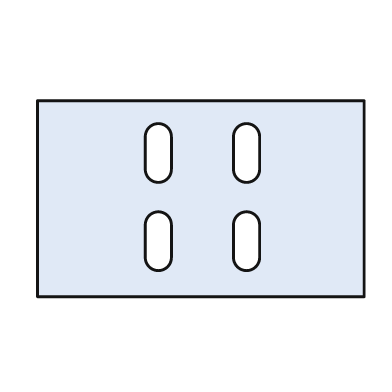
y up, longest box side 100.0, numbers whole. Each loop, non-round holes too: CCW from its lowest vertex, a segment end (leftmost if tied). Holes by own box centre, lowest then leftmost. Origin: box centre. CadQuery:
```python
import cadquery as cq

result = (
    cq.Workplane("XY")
    .moveTo(-50.0, -30.0)
    .lineTo(50.0, -30.0)
    .lineTo(50.0, 30.0)
    .lineTo(-50.0, 30.0)
    .close()
    .moveTo(-17.0, -18.0)
    .threePointArc((-13.0, -22.0), (-9.0, -18.0))
    .lineTo(-9.0, -8.0)
    .threePointArc((-13.0, -4.0), (-17.0, -8.0))
    .close()
    .moveTo(10.0, -18.0)
    .threePointArc((14.0, -22.0), (18.0, -18.0))
    .lineTo(18.0, -8.0)
    .threePointArc((14.0, -4.0), (10.0, -8.0))
    .close()
    .moveTo(-17.0, 9.0)
    .threePointArc((-13.0, 5.0), (-9.0, 9.0))
    .lineTo(-9.0, 19.0)
    .threePointArc((-13.0, 23.0), (-17.0, 19.0))
    .close()
    .moveTo(10.0, 9.0)
    .threePointArc((14.0, 5.0), (18.0, 9.0))
    .lineTo(18.0, 19.0)
    .threePointArc((14.0, 23.0), (10.0, 19.0))
    .close()
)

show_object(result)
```